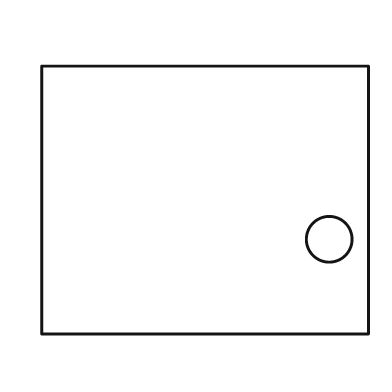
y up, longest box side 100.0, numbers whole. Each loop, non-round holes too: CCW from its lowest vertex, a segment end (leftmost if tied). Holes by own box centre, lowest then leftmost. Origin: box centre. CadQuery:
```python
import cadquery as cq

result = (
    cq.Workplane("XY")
    .moveTo(-50.0, -41.0)
    .lineTo(50.0, -41.0)
    .lineTo(50.0, 41.0)
    .lineTo(-50.0, 41.0)
    .close()
    .moveTo(38.0, -12.0)
    .circle(7.0)
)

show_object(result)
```